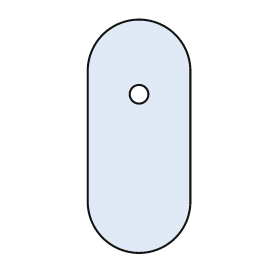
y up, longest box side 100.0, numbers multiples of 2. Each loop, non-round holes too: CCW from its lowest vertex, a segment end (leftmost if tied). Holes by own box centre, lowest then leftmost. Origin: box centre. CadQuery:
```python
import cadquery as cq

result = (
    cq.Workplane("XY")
    .moveTo(-22.0, -28.0)
    .threePointArc((0.0, -50.0), (22.0, -28.0))
    .lineTo(22.0, 28.0)
    .threePointArc((0.0, 50.0), (-22.0, 28.0))
    .close()
    .moveTo(0.0, 18.0)
    .circle(4.0)
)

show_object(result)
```